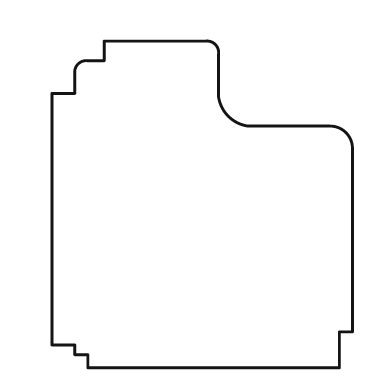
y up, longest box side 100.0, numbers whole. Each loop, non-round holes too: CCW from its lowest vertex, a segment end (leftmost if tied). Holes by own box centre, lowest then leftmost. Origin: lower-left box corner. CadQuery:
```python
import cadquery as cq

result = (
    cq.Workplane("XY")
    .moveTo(11.0, 0.0)
    .lineTo(88.0, 0.0)
    .lineTo(88.0, 11.0)
    .lineTo(92.0, 11.0)
    .lineTo(92.0, 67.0)
    .threePointArc((90.0, 72.0), (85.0, 74.0))
    .lineTo(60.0, 74.0)
    .threePointArc((54.0, 77.0), (51.0, 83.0))
    .lineTo(51.0, 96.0)
    .threePointArc((50.0, 99.0), (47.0, 100.0))
    .lineTo(16.0, 100.0)
    .lineTo(16.0, 94.0)
    .lineTo(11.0, 94.0)
    .threePointArc((8.0, 93.0), (7.0, 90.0))
    .lineTo(7.0, 84.0)
    .lineTo(0.0, 84.0)
    .lineTo(0.0, 7.0)
    .lineTo(7.0, 7.0)
    .lineTo(7.0, 4.0)
    .lineTo(11.0, 4.0)
    .close()
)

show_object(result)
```